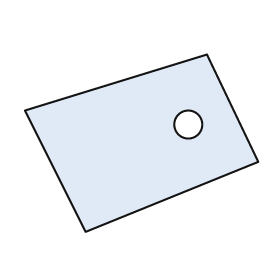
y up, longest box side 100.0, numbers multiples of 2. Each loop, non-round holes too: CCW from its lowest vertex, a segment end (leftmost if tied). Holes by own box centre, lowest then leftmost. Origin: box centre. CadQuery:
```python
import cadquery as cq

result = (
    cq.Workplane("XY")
    .moveTo(-24.0, -38.0)
    .lineTo(50.0, -8.0)
    .lineTo(28.0, 38.0)
    .lineTo(-50.0, 14.0)
    .close()
    .moveTo(20.0, 8.0)
    .circle(6.0)
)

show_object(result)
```